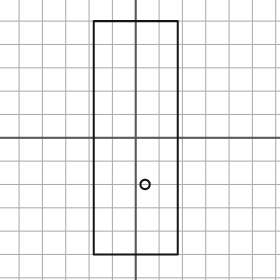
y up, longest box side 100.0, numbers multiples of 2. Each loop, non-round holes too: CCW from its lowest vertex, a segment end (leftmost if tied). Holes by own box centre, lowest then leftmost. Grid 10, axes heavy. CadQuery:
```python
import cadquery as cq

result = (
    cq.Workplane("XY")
    .moveTo(-18.0, -50.0)
    .lineTo(18.0, -50.0)
    .lineTo(18.0, 50.0)
    .lineTo(-18.0, 50.0)
    .close()
    .moveTo(4.0, -20.0)
    .circle(2.0)
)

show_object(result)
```